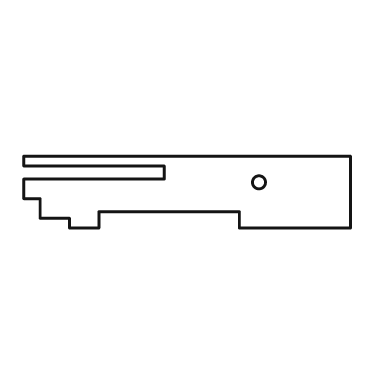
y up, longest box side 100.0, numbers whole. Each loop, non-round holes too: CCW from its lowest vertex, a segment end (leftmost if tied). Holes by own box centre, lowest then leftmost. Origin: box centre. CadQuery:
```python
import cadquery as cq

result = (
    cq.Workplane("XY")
    .moveTo(-36.0, -11.0)
    .lineTo(-27.0, -11.0)
    .lineTo(-27.0, -6.0)
    .lineTo(16.0, -6.0)
    .lineTo(16.0, -11.0)
    .lineTo(50.0, -11.0)
    .lineTo(50.0, 11.0)
    .lineTo(-50.0, 11.0)
    .lineTo(-50.0, 8.0)
    .lineTo(-7.0, 8.0)
    .lineTo(-7.0, 4.0)
    .lineTo(-50.0, 4.0)
    .lineTo(-50.0, -2.0)
    .lineTo(-45.0, -2.0)
    .lineTo(-45.0, -8.0)
    .lineTo(-36.0, -8.0)
    .close()
    .moveTo(22.0, 3.0)
    .circle(2.0)
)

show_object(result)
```